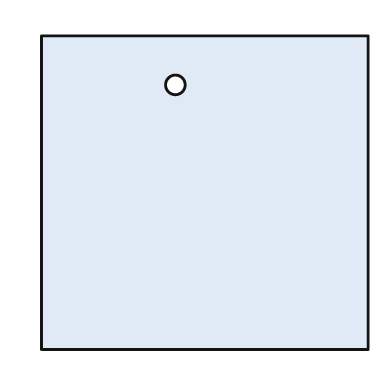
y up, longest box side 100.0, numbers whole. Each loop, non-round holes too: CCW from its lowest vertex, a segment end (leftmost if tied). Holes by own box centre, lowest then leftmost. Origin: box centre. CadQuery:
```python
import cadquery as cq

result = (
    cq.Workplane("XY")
    .moveTo(-50.0, -48.0)
    .lineTo(50.0, -48.0)
    .lineTo(50.0, 48.0)
    .lineTo(-50.0, 48.0)
    .close()
    .moveTo(-9.0, 33.0)
    .circle(3.0)
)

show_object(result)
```